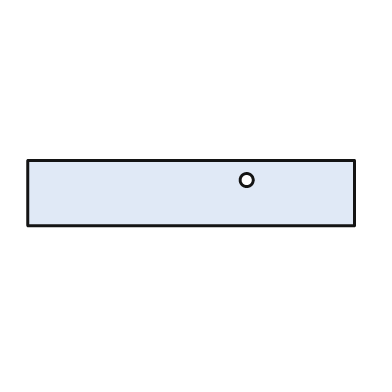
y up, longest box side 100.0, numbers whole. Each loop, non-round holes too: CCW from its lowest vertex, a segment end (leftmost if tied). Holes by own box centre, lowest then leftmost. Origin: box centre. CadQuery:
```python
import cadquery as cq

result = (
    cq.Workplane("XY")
    .moveTo(-50.0, -10.0)
    .lineTo(50.0, -10.0)
    .lineTo(50.0, 10.0)
    .lineTo(-50.0, 10.0)
    .close()
    .moveTo(17.0, 4.0)
    .circle(2.0)
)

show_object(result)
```